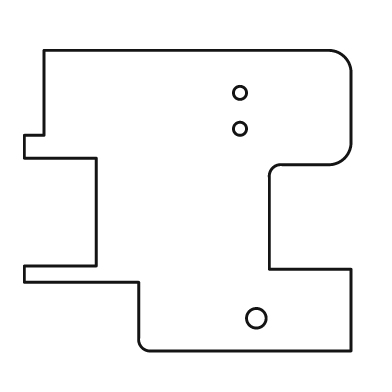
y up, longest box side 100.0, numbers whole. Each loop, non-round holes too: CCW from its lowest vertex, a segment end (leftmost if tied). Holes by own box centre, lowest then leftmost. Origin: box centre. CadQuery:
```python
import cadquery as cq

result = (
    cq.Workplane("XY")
    .moveTo(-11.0, -46.0)
    .lineTo(50.0, -46.0)
    .lineTo(50.0, -21.0)
    .lineTo(25.0, -21.0)
    .lineTo(25.0, 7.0)
    .threePointArc((26.0, 10.0), (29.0, 11.0))
    .lineTo(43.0, 11.0)
    .threePointArc((48.0, 13.0), (50.0, 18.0))
    .lineTo(50.0, 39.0)
    .threePointArc((48.0, 44.0), (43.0, 46.0))
    .lineTo(-44.0, 46.0)
    .lineTo(-44.0, 20.0)
    .lineTo(-50.0, 20.0)
    .lineTo(-50.0, 13.0)
    .lineTo(-28.0, 13.0)
    .lineTo(-28.0, -20.0)
    .lineTo(-50.0, -20.0)
    .lineTo(-50.0, -25.0)
    .lineTo(-15.0, -25.0)
    .lineTo(-15.0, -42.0)
    .threePointArc((-14.0, -45.0), (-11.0, -46.0))
    .close()
    .moveTo(21.0, -36.0)
    .circle(3.0)
    .moveTo(16.0, 22.0)
    .circle(2.0)
    .moveTo(16.0, 33.0)
    .circle(2.0)
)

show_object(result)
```